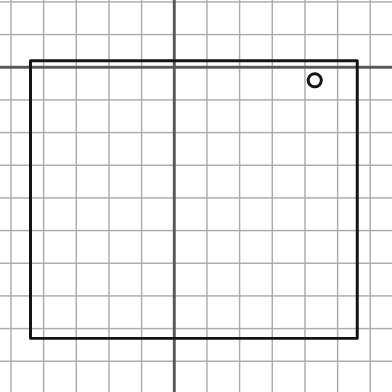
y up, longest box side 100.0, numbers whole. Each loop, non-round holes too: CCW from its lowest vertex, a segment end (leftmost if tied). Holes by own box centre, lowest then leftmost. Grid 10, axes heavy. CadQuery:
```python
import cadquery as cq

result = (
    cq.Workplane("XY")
    .moveTo(-44.0, -83.0)
    .lineTo(56.0, -83.0)
    .lineTo(56.0, 2.0)
    .lineTo(-44.0, 2.0)
    .close()
    .moveTo(43.0, -4.0)
    .circle(2.0)
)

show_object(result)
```